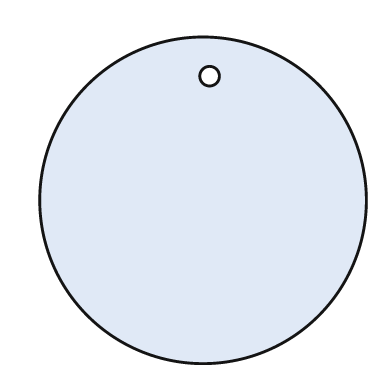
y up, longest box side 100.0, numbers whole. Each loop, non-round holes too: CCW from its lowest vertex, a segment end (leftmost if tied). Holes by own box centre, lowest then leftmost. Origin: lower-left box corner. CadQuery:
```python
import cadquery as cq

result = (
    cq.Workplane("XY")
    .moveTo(50.0, 50.0)
    .circle(50.0)
    .moveTo(52.0, 88.0)
    .circle(3.0)
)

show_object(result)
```